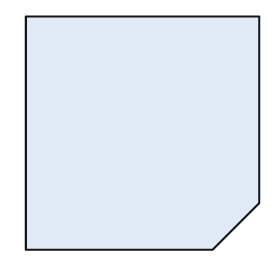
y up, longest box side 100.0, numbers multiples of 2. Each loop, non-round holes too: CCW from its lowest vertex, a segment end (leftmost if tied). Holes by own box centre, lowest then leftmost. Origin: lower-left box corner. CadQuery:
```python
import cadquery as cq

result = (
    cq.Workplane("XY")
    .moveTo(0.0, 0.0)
    .lineTo(80.0, 0.0)
    .lineTo(100.0, 20.0)
    .lineTo(100.0, 100.0)
    .lineTo(0.0, 100.0)
    .close()
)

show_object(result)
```